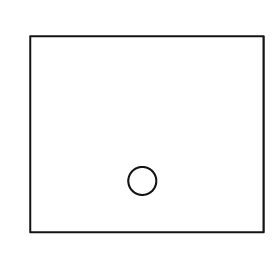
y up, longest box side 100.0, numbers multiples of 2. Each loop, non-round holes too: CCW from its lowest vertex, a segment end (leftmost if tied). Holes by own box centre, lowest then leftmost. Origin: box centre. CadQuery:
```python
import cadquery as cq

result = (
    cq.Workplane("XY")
    .moveTo(-50.0, -42.0)
    .lineTo(50.0, -42.0)
    .lineTo(50.0, 42.0)
    .lineTo(-50.0, 42.0)
    .close()
    .moveTo(-2.0, -20.0)
    .circle(6.0)
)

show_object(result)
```